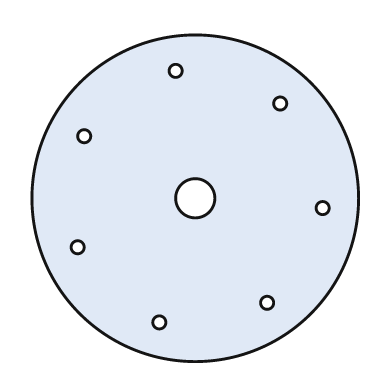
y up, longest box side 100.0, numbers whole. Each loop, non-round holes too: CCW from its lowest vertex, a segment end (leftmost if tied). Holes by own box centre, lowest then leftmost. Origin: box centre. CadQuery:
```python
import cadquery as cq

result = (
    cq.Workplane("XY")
    .moveTo(0.0, 0.0)
    .circle(50.0)
    .moveTo(-11.0, -38.0)
    .circle(2.0)
    .moveTo(22.0, -32.0)
    .circle(2.0)
    .moveTo(-36.0, -15.0)
    .circle(2.0)
    .moveTo(39.0, -3.0)
    .circle(2.0)
    .moveTo(0.0, 0.0)
    .circle(6.0)
    .moveTo(-34.0, 19.0)
    .circle(2.0)
    .moveTo(26.0, 29.0)
    .circle(2.0)
    .moveTo(-6.0, 39.0)
    .circle(2.0)
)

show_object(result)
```